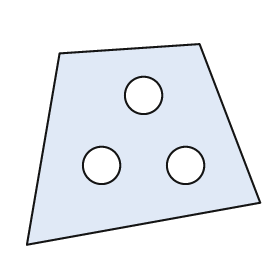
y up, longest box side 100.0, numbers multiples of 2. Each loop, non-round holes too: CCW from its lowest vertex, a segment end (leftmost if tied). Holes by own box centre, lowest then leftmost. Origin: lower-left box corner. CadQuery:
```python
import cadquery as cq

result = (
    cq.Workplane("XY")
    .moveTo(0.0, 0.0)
    .lineTo(100.0, 18.0)
    .lineTo(74.0, 86.0)
    .lineTo(14.0, 82.0)
    .close()
    .moveTo(32.0, 34.0)
    .circle(8.0)
    .moveTo(68.0, 34.0)
    .circle(8.0)
    .moveTo(50.0, 64.0)
    .circle(8.0)
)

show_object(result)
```